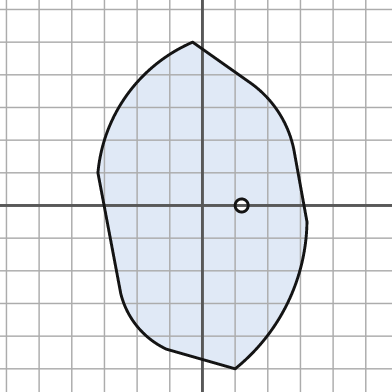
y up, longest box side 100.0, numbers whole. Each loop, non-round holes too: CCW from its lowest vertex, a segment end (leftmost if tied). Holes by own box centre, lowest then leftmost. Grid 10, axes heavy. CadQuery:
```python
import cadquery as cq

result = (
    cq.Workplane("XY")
    .moveTo(10.0, -50.0)
    .threePointArc((26.0, -30.0), (32.0, -5.0))
    .lineTo(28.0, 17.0)
    .threePointArc((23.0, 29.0), (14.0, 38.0))
    .lineTo(-3.0, 50.0)
    .threePointArc((-23.0, 34.0), (-32.0, 10.0))
    .lineTo(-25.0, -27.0)
    .threePointArc((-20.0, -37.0), (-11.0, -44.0))
    .close()
    .moveTo(12.0, 0.0)
    .circle(2.0)
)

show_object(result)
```